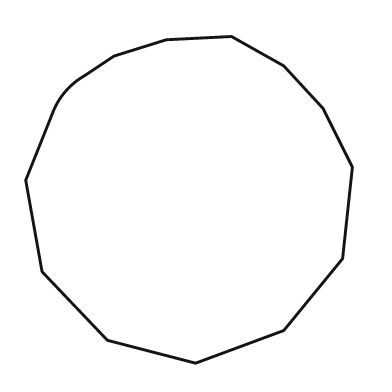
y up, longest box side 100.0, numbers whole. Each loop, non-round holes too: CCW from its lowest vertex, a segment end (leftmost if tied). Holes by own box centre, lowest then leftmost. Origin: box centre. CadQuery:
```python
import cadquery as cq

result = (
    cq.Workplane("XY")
    .moveTo(2.0, -50.0)
    .lineTo(29.0, -40.0)
    .lineTo(47.0, -18.0)
    .lineTo(50.0, 10.0)
    .lineTo(41.0, 28.0)
    .lineTo(29.0, 41.0)
    .lineTo(13.0, 50.0)
    .lineTo(-7.0, 49.0)
    .lineTo(-23.0, 44.0)
    .lineTo(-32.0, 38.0)
    .threePointArc((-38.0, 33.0), (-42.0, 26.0))
    .lineTo(-50.0, 6.0)
    .lineTo(-45.0, -22.0)
    .lineTo(-25.0, -43.0)
    .close()
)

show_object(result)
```